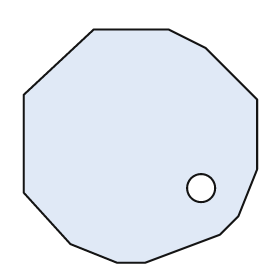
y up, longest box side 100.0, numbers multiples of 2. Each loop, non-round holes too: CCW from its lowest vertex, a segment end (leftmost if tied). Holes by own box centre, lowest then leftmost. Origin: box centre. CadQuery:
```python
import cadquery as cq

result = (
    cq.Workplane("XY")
    .moveTo(-10.0, -50.0)
    .lineTo(2.0, -50.0)
    .lineTo(34.0, -38.0)
    .lineTo(42.0, -30.0)
    .lineTo(50.0, -10.0)
    .lineTo(50.0, 20.0)
    .lineTo(28.0, 42.0)
    .lineTo(12.0, 50.0)
    .lineTo(-20.0, 50.0)
    .lineTo(-50.0, 22.0)
    .lineTo(-50.0, -20.0)
    .lineTo(-30.0, -42.0)
    .close()
    .moveTo(26.0, -18.0)
    .circle(6.0)
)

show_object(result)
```